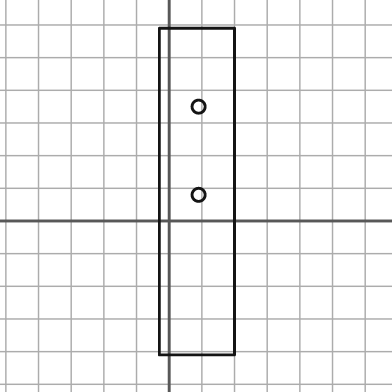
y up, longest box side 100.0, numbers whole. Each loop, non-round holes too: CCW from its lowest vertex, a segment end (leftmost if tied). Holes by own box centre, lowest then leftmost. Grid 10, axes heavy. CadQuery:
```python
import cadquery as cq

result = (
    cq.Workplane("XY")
    .moveTo(-3.0, -41.0)
    .lineTo(20.0, -41.0)
    .lineTo(20.0, 59.0)
    .lineTo(-3.0, 59.0)
    .close()
    .moveTo(9.0, 8.0)
    .circle(2.0)
    .moveTo(9.0, 35.0)
    .circle(2.0)
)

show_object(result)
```